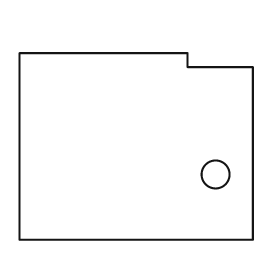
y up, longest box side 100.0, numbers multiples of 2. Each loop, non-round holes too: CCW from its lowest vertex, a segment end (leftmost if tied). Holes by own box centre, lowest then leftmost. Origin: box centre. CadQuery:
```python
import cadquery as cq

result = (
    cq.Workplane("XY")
    .moveTo(-50.0, -40.0)
    .lineTo(50.0, -40.0)
    .lineTo(50.0, 34.0)
    .lineTo(22.0, 34.0)
    .lineTo(22.0, 40.0)
    .lineTo(-50.0, 40.0)
    .close()
    .moveTo(34.0, -12.0)
    .circle(6.0)
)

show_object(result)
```